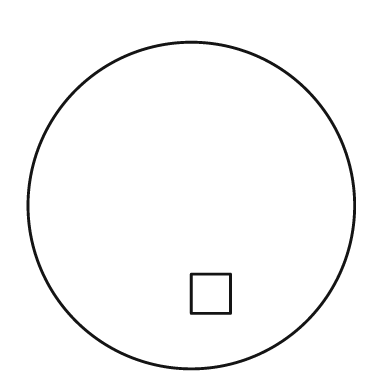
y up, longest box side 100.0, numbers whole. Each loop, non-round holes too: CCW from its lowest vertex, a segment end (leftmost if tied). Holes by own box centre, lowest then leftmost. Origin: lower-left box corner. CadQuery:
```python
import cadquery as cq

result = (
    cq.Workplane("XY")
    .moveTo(50.0, 50.0)
    .circle(50.0)
    .moveTo(50.0, 17.0)
    .lineTo(62.0, 17.0)
    .lineTo(62.0, 29.0)
    .lineTo(50.0, 29.0)
    .close()
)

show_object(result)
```